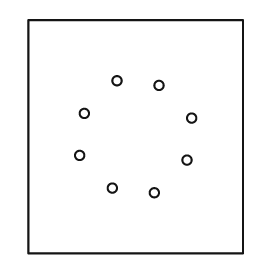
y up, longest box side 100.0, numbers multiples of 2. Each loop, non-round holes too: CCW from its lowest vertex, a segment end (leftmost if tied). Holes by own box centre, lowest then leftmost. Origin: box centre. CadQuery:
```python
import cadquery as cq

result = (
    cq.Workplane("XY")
    .moveTo(-46.0, -50.0)
    .lineTo(46.0, -50.0)
    .lineTo(46.0, 50.0)
    .lineTo(-46.0, 50.0)
    .close()
    .moveTo(8.0, -24.0)
    .circle(2.0)
    .moveTo(-10.0, -22.0)
    .circle(2.0)
    .moveTo(22.0, -10.0)
    .circle(2.0)
    .moveTo(-24.0, -8.0)
    .circle(2.0)
    .moveTo(24.0, 8.0)
    .circle(2.0)
    .moveTo(-22.0, 10.0)
    .circle(2.0)
    .moveTo(10.0, 22.0)
    .circle(2.0)
    .moveTo(-8.0, 24.0)
    .circle(2.0)
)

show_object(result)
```